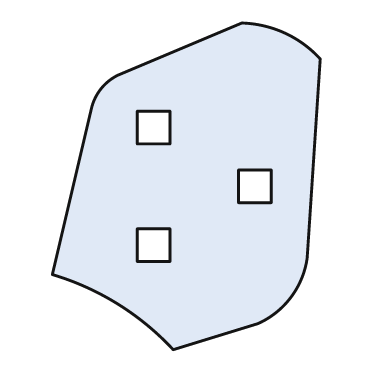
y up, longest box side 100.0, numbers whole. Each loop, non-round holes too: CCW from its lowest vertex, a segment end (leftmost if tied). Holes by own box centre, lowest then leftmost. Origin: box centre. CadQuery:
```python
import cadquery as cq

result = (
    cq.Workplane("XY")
    .moveTo(-4.0, -50.0)
    .lineTo(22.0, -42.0)
    .threePointArc((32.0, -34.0), (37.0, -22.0))
    .lineTo(41.0, 39.0)
    .threePointArc((30.0, 47.0), (17.0, 50.0))
    .lineTo(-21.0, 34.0)
    .threePointArc((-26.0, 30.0), (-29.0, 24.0))
    .lineTo(-41.0, -27.0)
    .threePointArc((-21.0, -36.0), (-4.0, -50.0))
    .close()
    .moveTo(-15.0, -23.0)
    .lineTo(-5.0, -23.0)
    .lineTo(-5.0, -13.0)
    .lineTo(-15.0, -13.0)
    .close()
    .moveTo(16.0, -5.0)
    .lineTo(26.0, -5.0)
    .lineTo(26.0, 5.0)
    .lineTo(16.0, 5.0)
    .close()
    .moveTo(-15.0, 13.0)
    .lineTo(-5.0, 13.0)
    .lineTo(-5.0, 23.0)
    .lineTo(-15.0, 23.0)
    .close()
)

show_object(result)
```